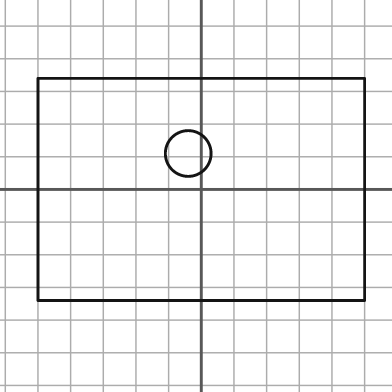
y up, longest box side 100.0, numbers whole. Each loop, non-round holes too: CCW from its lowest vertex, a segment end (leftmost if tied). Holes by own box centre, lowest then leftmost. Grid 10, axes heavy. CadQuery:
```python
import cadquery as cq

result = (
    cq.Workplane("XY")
    .moveTo(-50.0, -34.0)
    .lineTo(50.0, -34.0)
    .lineTo(50.0, 34.0)
    .lineTo(-50.0, 34.0)
    .close()
    .moveTo(-4.0, 11.0)
    .circle(7.0)
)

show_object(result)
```